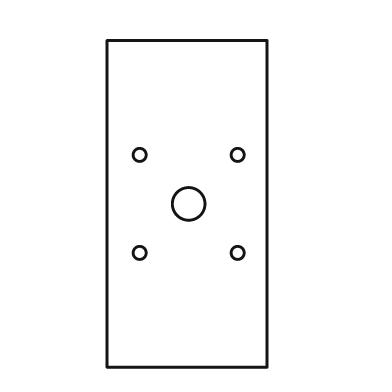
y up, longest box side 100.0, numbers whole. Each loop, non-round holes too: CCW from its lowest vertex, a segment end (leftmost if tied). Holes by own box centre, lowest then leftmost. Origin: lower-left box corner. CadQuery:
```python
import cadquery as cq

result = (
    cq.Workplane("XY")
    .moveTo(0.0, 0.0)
    .lineTo(49.0, 0.0)
    .lineTo(49.0, 100.0)
    .lineTo(0.0, 100.0)
    .close()
    .moveTo(10.0, 35.0)
    .circle(2.0)
    .moveTo(40.0, 35.0)
    .circle(2.0)
    .moveTo(25.0, 50.0)
    .circle(5.0)
    .moveTo(10.0, 65.0)
    .circle(2.0)
    .moveTo(40.0, 65.0)
    .circle(2.0)
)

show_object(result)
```